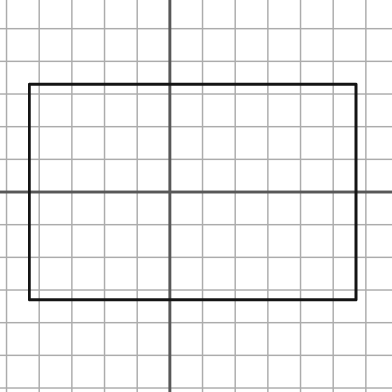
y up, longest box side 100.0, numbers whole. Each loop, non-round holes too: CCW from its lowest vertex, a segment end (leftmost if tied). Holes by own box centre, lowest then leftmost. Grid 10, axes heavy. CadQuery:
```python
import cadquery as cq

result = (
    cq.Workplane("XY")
    .moveTo(-43.0, -33.0)
    .lineTo(57.0, -33.0)
    .lineTo(57.0, 33.0)
    .lineTo(-43.0, 33.0)
    .close()
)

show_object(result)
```